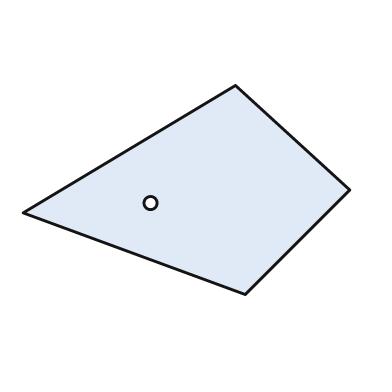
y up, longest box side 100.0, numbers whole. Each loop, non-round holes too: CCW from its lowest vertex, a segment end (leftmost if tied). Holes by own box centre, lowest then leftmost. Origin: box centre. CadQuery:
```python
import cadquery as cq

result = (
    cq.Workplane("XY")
    .moveTo(18.0, -32.0)
    .lineTo(50.0, 0.0)
    .lineTo(15.0, 32.0)
    .lineTo(-50.0, -7.0)
    .close()
    .moveTo(-11.0, -4.0)
    .circle(2.0)
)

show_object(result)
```